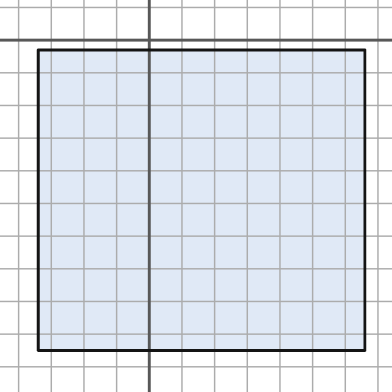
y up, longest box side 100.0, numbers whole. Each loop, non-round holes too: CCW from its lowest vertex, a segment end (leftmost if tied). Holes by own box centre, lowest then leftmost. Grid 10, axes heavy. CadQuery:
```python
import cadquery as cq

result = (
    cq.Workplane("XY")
    .moveTo(-34.0, -95.0)
    .lineTo(66.0, -95.0)
    .lineTo(66.0, -3.0)
    .lineTo(-34.0, -3.0)
    .close()
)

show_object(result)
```